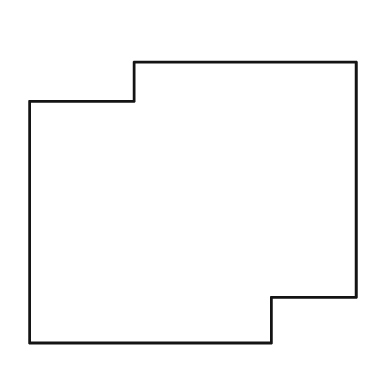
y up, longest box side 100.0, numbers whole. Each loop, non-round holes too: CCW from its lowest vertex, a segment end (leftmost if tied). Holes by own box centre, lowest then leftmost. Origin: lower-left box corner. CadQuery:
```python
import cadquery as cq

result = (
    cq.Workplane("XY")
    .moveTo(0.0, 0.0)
    .lineTo(74.0, 0.0)
    .lineTo(74.0, 14.0)
    .lineTo(100.0, 14.0)
    .lineTo(100.0, 86.0)
    .lineTo(32.0, 86.0)
    .lineTo(32.0, 74.0)
    .lineTo(0.0, 74.0)
    .close()
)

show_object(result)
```